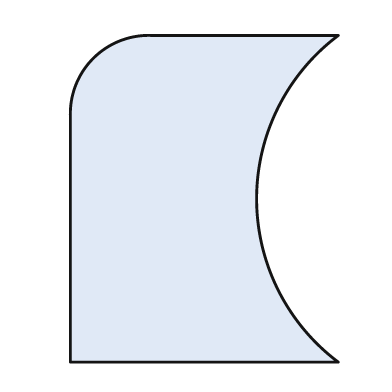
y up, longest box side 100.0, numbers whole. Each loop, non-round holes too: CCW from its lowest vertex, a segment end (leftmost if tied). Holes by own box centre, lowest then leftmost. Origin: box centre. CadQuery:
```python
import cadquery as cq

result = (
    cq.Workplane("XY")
    .moveTo(-41.0, -50.0)
    .lineTo(41.0, -50.0)
    .threePointArc((16.0, 0.0), (41.0, 50.0))
    .lineTo(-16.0, 50.0)
    .threePointArc((-34.0, 43.0), (-41.0, 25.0))
    .close()
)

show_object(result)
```